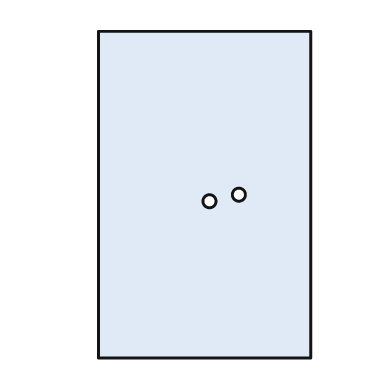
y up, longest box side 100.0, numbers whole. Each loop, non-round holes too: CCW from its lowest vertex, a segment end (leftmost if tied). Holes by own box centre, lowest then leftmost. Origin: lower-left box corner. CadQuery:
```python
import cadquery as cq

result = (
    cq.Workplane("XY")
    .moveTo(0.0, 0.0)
    .lineTo(65.0, 0.0)
    .lineTo(65.0, 100.0)
    .lineTo(0.0, 100.0)
    .close()
    .moveTo(34.0, 48.0)
    .circle(2.0)
    .moveTo(43.0, 50.0)
    .circle(2.0)
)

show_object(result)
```